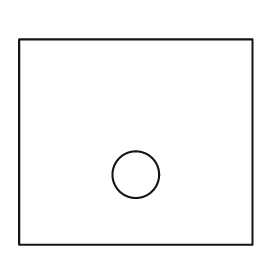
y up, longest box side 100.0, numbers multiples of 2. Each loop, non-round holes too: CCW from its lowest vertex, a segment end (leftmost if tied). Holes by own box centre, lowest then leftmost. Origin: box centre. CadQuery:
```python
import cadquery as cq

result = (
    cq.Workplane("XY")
    .moveTo(-50.0, -44.0)
    .lineTo(50.0, -44.0)
    .lineTo(50.0, 44.0)
    .lineTo(-50.0, 44.0)
    .close()
    .moveTo(0.0, -14.0)
    .circle(10.0)
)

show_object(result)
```